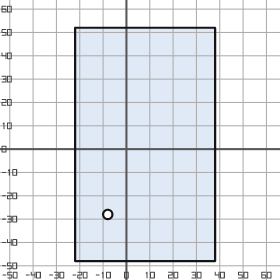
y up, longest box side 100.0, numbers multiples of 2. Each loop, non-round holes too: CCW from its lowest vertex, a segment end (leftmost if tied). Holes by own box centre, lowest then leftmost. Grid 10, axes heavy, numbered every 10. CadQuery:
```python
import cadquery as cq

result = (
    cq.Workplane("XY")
    .moveTo(-22.0, -48.0)
    .lineTo(38.0, -48.0)
    .lineTo(38.0, 52.0)
    .lineTo(-22.0, 52.0)
    .close()
    .moveTo(-8.0, -28.0)
    .circle(2.0)
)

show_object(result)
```